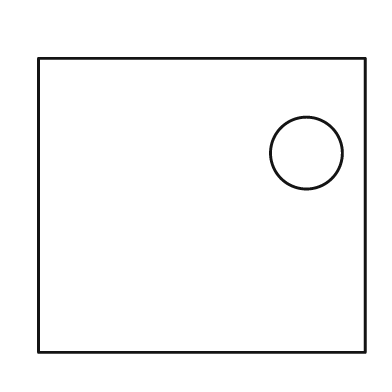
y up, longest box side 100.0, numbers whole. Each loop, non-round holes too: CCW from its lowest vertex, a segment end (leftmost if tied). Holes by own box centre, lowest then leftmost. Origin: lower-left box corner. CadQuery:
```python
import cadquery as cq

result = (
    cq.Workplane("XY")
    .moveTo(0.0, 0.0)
    .lineTo(100.0, 0.0)
    .lineTo(100.0, 90.0)
    .lineTo(0.0, 90.0)
    .close()
    .moveTo(82.0, 61.0)
    .circle(11.0)
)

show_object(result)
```